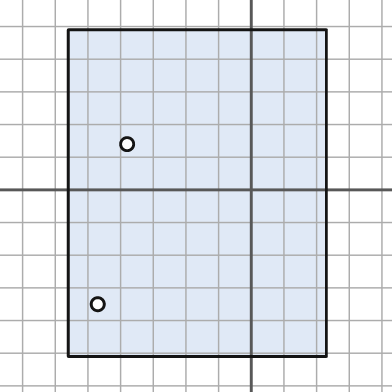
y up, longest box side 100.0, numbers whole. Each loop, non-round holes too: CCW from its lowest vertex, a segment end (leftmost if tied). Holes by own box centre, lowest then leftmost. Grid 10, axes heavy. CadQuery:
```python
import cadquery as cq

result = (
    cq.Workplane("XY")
    .moveTo(-56.0, -51.0)
    .lineTo(23.0, -51.0)
    .lineTo(23.0, 49.0)
    .lineTo(-56.0, 49.0)
    .close()
    .moveTo(-47.0, -35.0)
    .circle(2.0)
    .moveTo(-38.0, 14.0)
    .circle(2.0)
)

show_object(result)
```